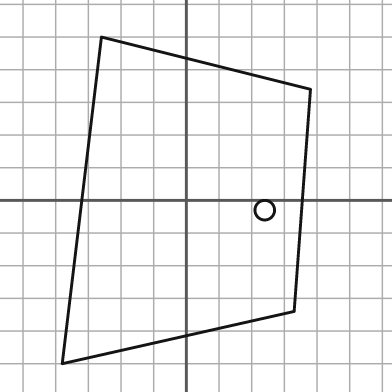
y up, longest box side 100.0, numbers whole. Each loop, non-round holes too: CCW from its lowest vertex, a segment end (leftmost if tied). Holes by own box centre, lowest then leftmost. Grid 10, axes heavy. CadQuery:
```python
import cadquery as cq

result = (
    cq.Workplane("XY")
    .moveTo(-38.0, -50.0)
    .lineTo(33.0, -34.0)
    .lineTo(38.0, 34.0)
    .lineTo(-26.0, 50.0)
    .close()
    .moveTo(24.0, -3.0)
    .circle(3.0)
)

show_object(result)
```